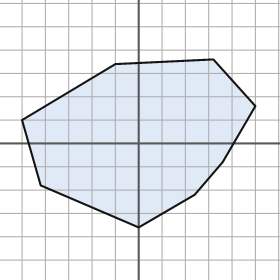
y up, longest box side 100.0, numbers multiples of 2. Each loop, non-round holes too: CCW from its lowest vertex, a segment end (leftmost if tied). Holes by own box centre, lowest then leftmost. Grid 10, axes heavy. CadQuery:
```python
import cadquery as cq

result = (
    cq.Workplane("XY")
    .moveTo(0.0, -36.0)
    .lineTo(24.0, -22.0)
    .lineTo(36.0, -8.0)
    .lineTo(50.0, 16.0)
    .lineTo(32.0, 36.0)
    .lineTo(-10.0, 34.0)
    .lineTo(-50.0, 10.0)
    .lineTo(-42.0, -18.0)
    .close()
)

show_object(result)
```